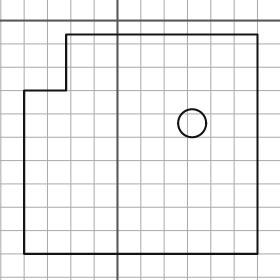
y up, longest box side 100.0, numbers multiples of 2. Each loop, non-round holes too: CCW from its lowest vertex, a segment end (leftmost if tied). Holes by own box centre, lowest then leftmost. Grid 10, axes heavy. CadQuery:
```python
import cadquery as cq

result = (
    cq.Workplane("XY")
    .moveTo(-40.0, -100.0)
    .lineTo(60.0, -100.0)
    .lineTo(60.0, -6.0)
    .lineTo(-22.0, -6.0)
    .lineTo(-22.0, -30.0)
    .lineTo(-40.0, -30.0)
    .close()
    .moveTo(32.0, -44.0)
    .circle(6.0)
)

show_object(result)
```